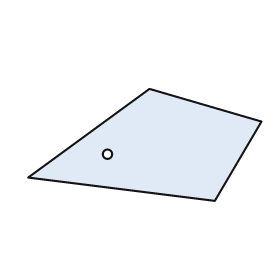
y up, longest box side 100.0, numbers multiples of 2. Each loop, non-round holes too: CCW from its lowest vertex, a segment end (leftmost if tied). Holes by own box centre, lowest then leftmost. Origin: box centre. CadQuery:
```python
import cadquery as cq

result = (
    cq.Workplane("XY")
    .moveTo(30.0, -24.0)
    .lineTo(50.0, 10.0)
    .lineTo(2.0, 24.0)
    .lineTo(-50.0, -14.0)
    .close()
    .moveTo(-16.0, -4.0)
    .circle(2.0)
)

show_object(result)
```